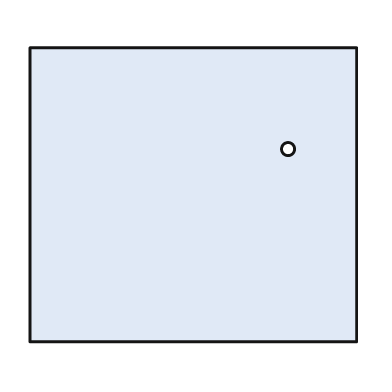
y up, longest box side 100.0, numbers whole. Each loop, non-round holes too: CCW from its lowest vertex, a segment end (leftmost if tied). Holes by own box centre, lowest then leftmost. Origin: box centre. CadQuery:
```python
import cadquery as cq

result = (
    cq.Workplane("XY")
    .moveTo(-50.0, -45.0)
    .lineTo(50.0, -45.0)
    .lineTo(50.0, 45.0)
    .lineTo(-50.0, 45.0)
    .close()
    .moveTo(29.0, 14.0)
    .circle(2.0)
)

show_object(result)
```